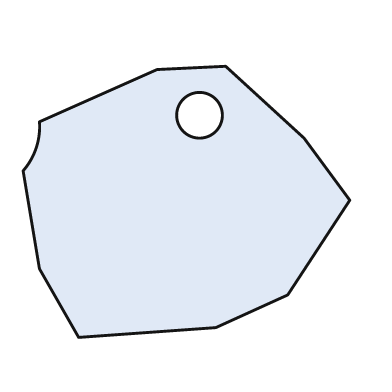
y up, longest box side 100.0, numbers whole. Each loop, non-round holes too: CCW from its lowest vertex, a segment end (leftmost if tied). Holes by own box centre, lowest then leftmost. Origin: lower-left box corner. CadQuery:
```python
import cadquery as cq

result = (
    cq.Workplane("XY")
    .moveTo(17.0, 0.0)
    .lineTo(59.0, 3.0)
    .lineTo(81.0, 13.0)
    .lineTo(100.0, 42.0)
    .lineTo(86.0, 61.0)
    .lineTo(62.0, 83.0)
    .lineTo(41.0, 82.0)
    .lineTo(5.0, 66.0)
    .threePointArc((4.0, 58.0), (0.0, 51.0))
    .lineTo(5.0, 21.0)
    .close()
    .moveTo(54.0, 68.0)
    .circle(7.0)
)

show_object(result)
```